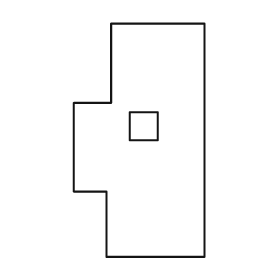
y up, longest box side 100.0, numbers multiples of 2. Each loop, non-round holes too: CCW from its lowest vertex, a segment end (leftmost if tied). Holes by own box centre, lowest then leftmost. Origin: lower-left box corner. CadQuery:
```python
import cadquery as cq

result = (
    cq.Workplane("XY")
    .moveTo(14.0, 0.0)
    .lineTo(56.0, 0.0)
    .lineTo(56.0, 100.0)
    .lineTo(16.0, 100.0)
    .lineTo(16.0, 66.0)
    .lineTo(0.0, 66.0)
    .lineTo(0.0, 28.0)
    .lineTo(14.0, 28.0)
    .close()
    .moveTo(24.0, 50.0)
    .lineTo(36.0, 50.0)
    .lineTo(36.0, 62.0)
    .lineTo(24.0, 62.0)
    .close()
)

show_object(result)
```